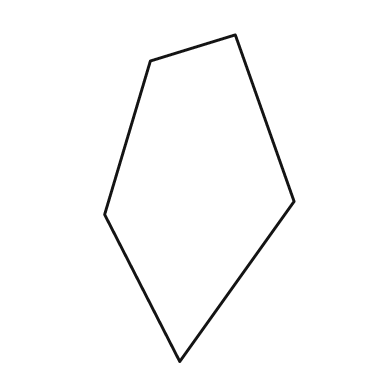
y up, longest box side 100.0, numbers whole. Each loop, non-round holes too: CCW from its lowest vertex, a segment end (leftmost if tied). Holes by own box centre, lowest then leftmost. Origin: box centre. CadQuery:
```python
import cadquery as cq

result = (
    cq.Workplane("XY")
    .moveTo(-6.0, -50.0)
    .lineTo(29.0, -1.0)
    .lineTo(11.0, 50.0)
    .lineTo(-15.0, 42.0)
    .lineTo(-29.0, -5.0)
    .close()
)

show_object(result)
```